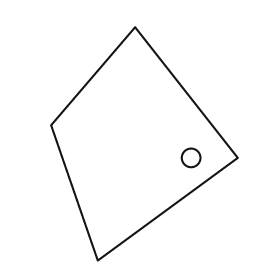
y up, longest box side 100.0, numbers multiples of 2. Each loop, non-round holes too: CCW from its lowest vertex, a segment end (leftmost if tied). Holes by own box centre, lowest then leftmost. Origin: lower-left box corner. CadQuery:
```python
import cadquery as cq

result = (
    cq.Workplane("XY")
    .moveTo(20.0, 0.0)
    .lineTo(80.0, 44.0)
    .lineTo(36.0, 100.0)
    .lineTo(0.0, 58.0)
    .close()
    .moveTo(60.0, 44.0)
    .circle(4.0)
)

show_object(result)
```